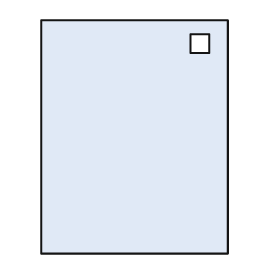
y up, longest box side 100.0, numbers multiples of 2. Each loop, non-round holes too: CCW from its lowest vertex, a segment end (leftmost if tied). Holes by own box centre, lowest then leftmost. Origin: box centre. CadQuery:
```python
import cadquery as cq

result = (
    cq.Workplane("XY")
    .moveTo(-40.0, -50.0)
    .lineTo(40.0, -50.0)
    .lineTo(40.0, 50.0)
    .lineTo(-40.0, 50.0)
    .close()
    .moveTo(24.0, 36.0)
    .lineTo(32.0, 36.0)
    .lineTo(32.0, 44.0)
    .lineTo(24.0, 44.0)
    .close()
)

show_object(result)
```